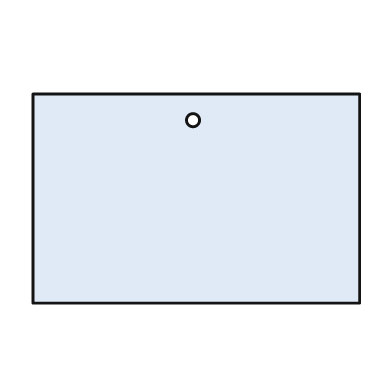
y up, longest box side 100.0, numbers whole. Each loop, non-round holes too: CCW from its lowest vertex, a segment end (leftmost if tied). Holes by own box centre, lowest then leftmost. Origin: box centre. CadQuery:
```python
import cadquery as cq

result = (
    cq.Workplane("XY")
    .moveTo(-50.0, -32.0)
    .lineTo(50.0, -32.0)
    .lineTo(50.0, 32.0)
    .lineTo(-50.0, 32.0)
    .close()
    .moveTo(-1.0, 24.0)
    .circle(2.0)
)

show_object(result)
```